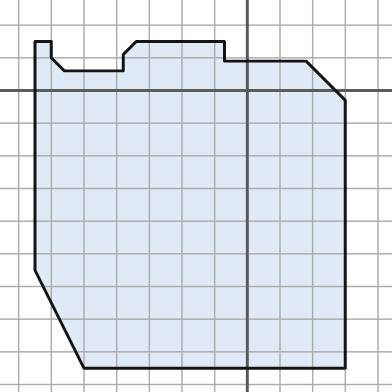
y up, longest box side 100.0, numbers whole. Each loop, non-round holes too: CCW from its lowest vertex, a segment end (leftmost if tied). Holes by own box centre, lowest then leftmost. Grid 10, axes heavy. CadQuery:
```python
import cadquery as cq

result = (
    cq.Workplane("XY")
    .moveTo(-50.0, -85.0)
    .lineTo(30.0, -85.0)
    .lineTo(30.0, -3.0)
    .lineTo(18.0, 9.0)
    .lineTo(-7.0, 9.0)
    .lineTo(-7.0, 15.0)
    .lineTo(-34.0, 15.0)
    .lineTo(-38.0, 11.0)
    .lineTo(-38.0, 6.0)
    .lineTo(-56.0, 6.0)
    .lineTo(-60.0, 10.0)
    .lineTo(-60.0, 15.0)
    .lineTo(-65.0, 15.0)
    .lineTo(-65.0, -55.0)
    .close()
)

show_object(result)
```